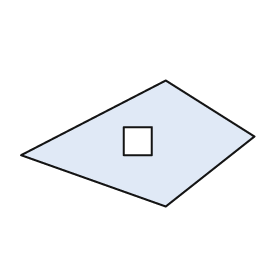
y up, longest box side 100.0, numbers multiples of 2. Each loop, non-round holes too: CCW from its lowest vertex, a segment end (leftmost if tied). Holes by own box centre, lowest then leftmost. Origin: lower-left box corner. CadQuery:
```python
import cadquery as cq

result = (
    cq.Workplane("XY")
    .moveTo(62.0, 0.0)
    .lineTo(100.0, 30.0)
    .lineTo(62.0, 54.0)
    .lineTo(0.0, 22.0)
    .close()
    .moveTo(44.0, 22.0)
    .lineTo(56.0, 22.0)
    .lineTo(56.0, 34.0)
    .lineTo(44.0, 34.0)
    .close()
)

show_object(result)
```